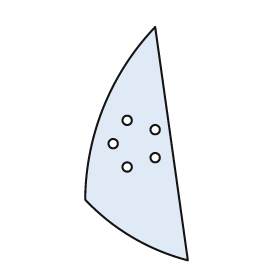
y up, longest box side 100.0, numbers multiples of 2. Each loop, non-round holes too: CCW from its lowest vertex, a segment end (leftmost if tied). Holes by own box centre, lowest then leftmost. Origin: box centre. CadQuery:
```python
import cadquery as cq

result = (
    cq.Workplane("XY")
    .moveTo(22.0, -50.0)
    .lineTo(8.0, 50.0)
    .threePointArc((-14.0, 16.0), (-22.0, -24.0))
    .threePointArc((-2.0, -40.0), (22.0, -50.0))
    .close()
    .moveTo(-4.0, -10.0)
    .circle(2.0)
    .moveTo(8.0, -6.0)
    .circle(2.0)
    .moveTo(-10.0, 0.0)
    .circle(2.0)
    .moveTo(8.0, 6.0)
    .circle(2.0)
    .moveTo(-4.0, 10.0)
    .circle(2.0)
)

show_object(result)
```